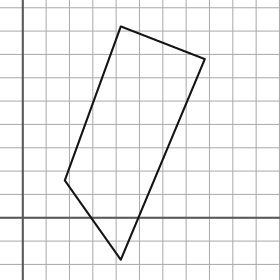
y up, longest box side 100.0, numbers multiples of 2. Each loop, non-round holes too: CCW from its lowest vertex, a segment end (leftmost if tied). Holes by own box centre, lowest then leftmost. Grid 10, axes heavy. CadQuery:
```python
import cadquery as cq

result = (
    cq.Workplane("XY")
    .moveTo(42.0, -18.0)
    .lineTo(78.0, 68.0)
    .lineTo(42.0, 82.0)
    .lineTo(18.0, 16.0)
    .close()
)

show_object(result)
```